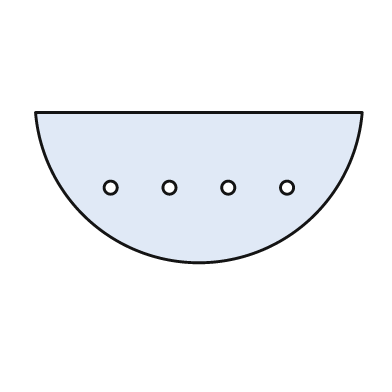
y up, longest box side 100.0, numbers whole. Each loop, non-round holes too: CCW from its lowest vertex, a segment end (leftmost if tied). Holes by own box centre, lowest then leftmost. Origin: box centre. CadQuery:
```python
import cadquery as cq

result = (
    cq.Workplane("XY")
    .moveTo(-50.0, 23.0)
    .threePointArc((0.0, -23.0), (50.0, 23.0))
    .close()
    .moveTo(-27.0, 0.0)
    .circle(2.0)
    .moveTo(-9.0, 0.0)
    .circle(2.0)
    .moveTo(9.0, 0.0)
    .circle(2.0)
    .moveTo(27.0, 0.0)
    .circle(2.0)
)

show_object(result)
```